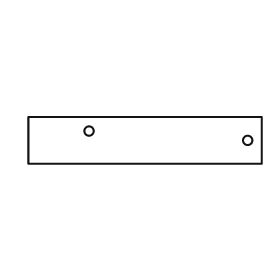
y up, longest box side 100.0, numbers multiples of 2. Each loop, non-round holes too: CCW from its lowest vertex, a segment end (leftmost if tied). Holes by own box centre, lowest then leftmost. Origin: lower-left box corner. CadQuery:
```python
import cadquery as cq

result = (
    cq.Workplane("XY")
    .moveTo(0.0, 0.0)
    .lineTo(100.0, 0.0)
    .lineTo(100.0, 20.0)
    .lineTo(0.0, 20.0)
    .close()
    .moveTo(94.0, 10.0)
    .circle(2.0)
    .moveTo(26.0, 14.0)
    .circle(2.0)
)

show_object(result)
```